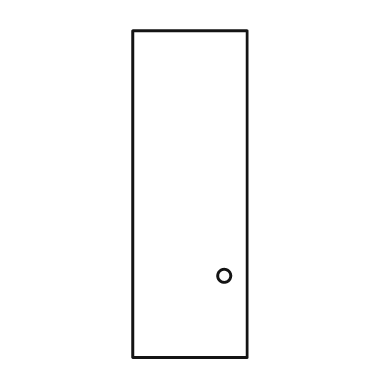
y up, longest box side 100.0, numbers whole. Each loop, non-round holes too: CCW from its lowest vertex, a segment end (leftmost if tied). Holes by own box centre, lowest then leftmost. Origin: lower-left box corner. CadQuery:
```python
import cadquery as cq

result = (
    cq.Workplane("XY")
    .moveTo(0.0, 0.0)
    .lineTo(35.0, 0.0)
    .lineTo(35.0, 100.0)
    .lineTo(0.0, 100.0)
    .close()
    .moveTo(28.0, 25.0)
    .circle(2.0)
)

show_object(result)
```